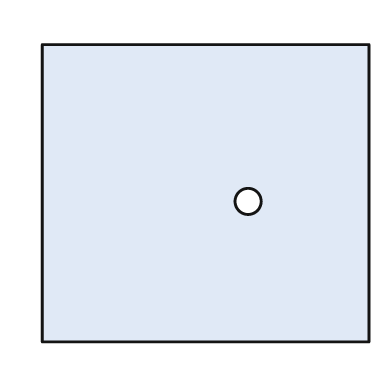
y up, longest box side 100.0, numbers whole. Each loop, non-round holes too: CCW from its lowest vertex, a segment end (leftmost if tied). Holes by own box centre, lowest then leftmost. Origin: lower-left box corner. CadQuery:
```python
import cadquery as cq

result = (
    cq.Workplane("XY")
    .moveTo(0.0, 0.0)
    .lineTo(100.0, 0.0)
    .lineTo(100.0, 91.0)
    .lineTo(0.0, 91.0)
    .close()
    .moveTo(63.0, 43.0)
    .circle(4.0)
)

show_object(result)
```